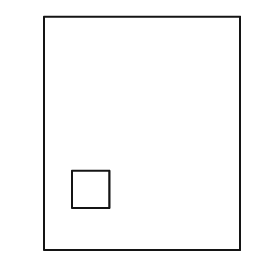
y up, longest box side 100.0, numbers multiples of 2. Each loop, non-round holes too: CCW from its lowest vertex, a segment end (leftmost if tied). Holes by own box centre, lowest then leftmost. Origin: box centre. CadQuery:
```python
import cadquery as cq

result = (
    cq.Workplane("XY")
    .moveTo(-42.0, -50.0)
    .lineTo(42.0, -50.0)
    .lineTo(42.0, 50.0)
    .lineTo(-42.0, 50.0)
    .close()
    .moveTo(-30.0, -32.0)
    .lineTo(-14.0, -32.0)
    .lineTo(-14.0, -16.0)
    .lineTo(-30.0, -16.0)
    .close()
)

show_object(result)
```